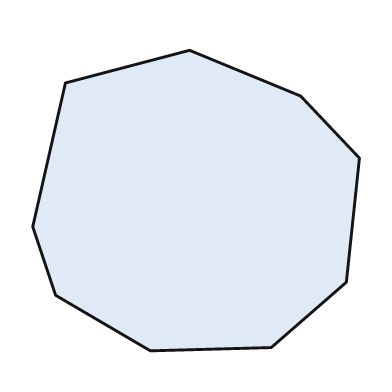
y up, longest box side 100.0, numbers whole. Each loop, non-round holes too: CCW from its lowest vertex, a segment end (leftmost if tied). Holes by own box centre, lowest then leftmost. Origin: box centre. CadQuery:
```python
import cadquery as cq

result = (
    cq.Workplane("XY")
    .moveTo(-14.0, -46.0)
    .lineTo(23.0, -45.0)
    .lineTo(46.0, -25.0)
    .lineTo(50.0, 13.0)
    .lineTo(32.0, 32.0)
    .lineTo(-2.0, 46.0)
    .lineTo(-40.0, 36.0)
    .lineTo(-50.0, -8.0)
    .lineTo(-43.0, -29.0)
    .close()
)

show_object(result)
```